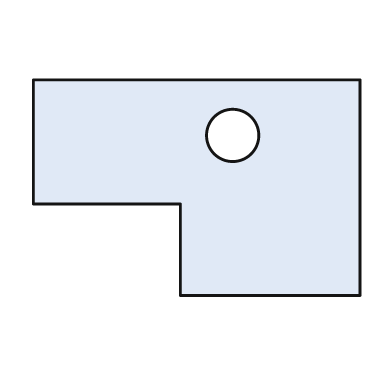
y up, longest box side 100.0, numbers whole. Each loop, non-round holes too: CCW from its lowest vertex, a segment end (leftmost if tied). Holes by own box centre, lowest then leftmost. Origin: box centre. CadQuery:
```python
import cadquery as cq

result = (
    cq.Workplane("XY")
    .moveTo(-5.0, -33.0)
    .lineTo(50.0, -33.0)
    .lineTo(50.0, 33.0)
    .lineTo(-50.0, 33.0)
    .lineTo(-50.0, -5.0)
    .lineTo(-5.0, -5.0)
    .close()
    .moveTo(11.0, 16.0)
    .circle(8.0)
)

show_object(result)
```